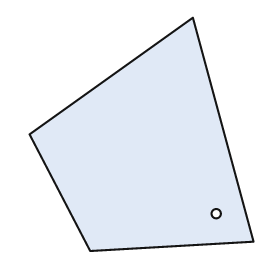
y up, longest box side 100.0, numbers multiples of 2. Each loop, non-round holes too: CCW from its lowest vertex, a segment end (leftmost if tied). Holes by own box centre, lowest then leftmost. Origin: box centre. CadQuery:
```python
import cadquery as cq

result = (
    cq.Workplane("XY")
    .moveTo(-22.0, -50.0)
    .lineTo(48.0, -46.0)
    .lineTo(22.0, 50.0)
    .lineTo(-48.0, 0.0)
    .close()
    .moveTo(32.0, -34.0)
    .circle(2.0)
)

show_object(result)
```